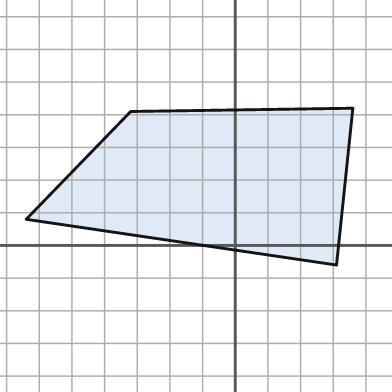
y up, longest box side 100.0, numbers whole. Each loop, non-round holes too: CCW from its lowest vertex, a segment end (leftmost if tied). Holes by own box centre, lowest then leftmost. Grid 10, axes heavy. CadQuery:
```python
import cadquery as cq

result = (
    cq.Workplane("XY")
    .moveTo(31.0, -6.0)
    .lineTo(36.0, 42.0)
    .lineTo(-32.0, 41.0)
    .lineTo(-64.0, 8.0)
    .close()
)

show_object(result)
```